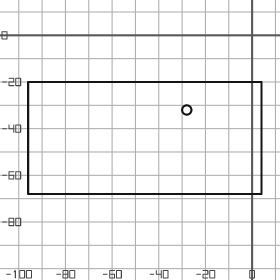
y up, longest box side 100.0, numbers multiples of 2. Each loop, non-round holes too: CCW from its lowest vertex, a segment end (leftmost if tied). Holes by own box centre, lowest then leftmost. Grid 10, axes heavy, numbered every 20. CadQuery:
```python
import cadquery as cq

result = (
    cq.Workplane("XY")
    .moveTo(-96.0, -68.0)
    .lineTo(4.0, -68.0)
    .lineTo(4.0, -20.0)
    .lineTo(-96.0, -20.0)
    .close()
    .moveTo(-28.0, -32.0)
    .circle(2.0)
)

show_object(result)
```